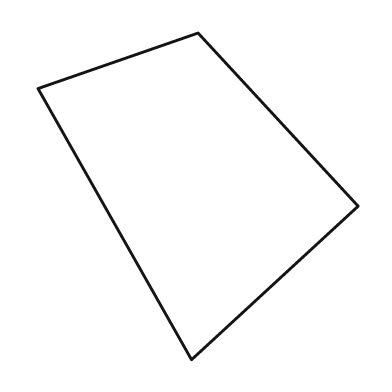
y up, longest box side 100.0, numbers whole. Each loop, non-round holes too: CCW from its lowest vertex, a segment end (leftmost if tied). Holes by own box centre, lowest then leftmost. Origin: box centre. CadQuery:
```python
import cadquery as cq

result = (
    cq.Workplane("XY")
    .moveTo(-2.0, -50.0)
    .lineTo(49.0, -3.0)
    .lineTo(0.0, 50.0)
    .lineTo(-49.0, 33.0)
    .close()
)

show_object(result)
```